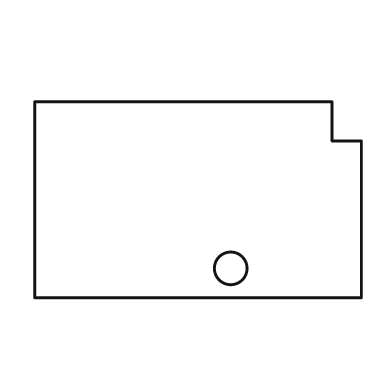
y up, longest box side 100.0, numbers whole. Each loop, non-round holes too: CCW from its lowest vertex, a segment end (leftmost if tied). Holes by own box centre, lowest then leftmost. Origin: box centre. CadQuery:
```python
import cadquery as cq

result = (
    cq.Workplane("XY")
    .moveTo(-50.0, -30.0)
    .lineTo(50.0, -30.0)
    .lineTo(50.0, 18.0)
    .lineTo(41.0, 18.0)
    .lineTo(41.0, 30.0)
    .lineTo(-50.0, 30.0)
    .close()
    .moveTo(10.0, -21.0)
    .circle(5.0)
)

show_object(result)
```